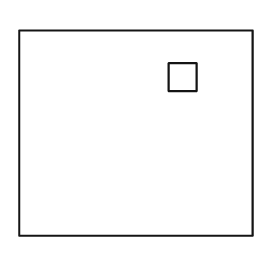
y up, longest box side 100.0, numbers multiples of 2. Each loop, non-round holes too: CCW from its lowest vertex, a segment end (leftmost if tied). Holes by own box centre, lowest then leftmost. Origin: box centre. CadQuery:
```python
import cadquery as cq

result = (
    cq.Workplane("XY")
    .moveTo(-50.0, -44.0)
    .lineTo(50.0, -44.0)
    .lineTo(50.0, 44.0)
    .lineTo(-50.0, 44.0)
    .close()
    .moveTo(14.0, 18.0)
    .lineTo(26.0, 18.0)
    .lineTo(26.0, 30.0)
    .lineTo(14.0, 30.0)
    .close()
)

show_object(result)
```